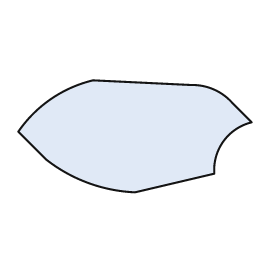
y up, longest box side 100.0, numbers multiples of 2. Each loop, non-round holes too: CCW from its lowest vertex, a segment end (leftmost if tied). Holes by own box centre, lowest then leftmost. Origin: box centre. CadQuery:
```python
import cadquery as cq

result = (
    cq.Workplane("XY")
    .moveTo(0.0, -24.0)
    .lineTo(34.0, -16.0)
    .threePointArc((38.0, -2.0), (50.0, 6.0))
    .lineTo(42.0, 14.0)
    .threePointArc((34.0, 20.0), (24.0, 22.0))
    .lineTo(-18.0, 24.0)
    .threePointArc((-36.0, 16.0), (-50.0, 2.0))
    .lineTo(-38.0, -10.0)
    .threePointArc((-20.0, -20.0), (0.0, -24.0))
    .close()
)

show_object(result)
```